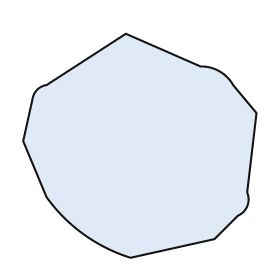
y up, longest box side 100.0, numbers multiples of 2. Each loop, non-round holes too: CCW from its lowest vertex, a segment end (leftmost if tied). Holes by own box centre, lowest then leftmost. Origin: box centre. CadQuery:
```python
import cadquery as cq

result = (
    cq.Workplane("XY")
    .moveTo(-4.0, -48.0)
    .lineTo(32.0, -40.0)
    .lineTo(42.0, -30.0)
    .threePointArc((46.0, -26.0), (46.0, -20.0))
    .lineTo(50.0, 14.0)
    .lineTo(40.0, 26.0)
    .threePointArc((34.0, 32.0), (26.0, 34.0))
    .lineTo(-6.0, 48.0)
    .lineTo(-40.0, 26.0)
    .threePointArc((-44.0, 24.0), (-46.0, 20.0))
    .lineTo(-50.0, 2.0)
    .lineTo(-40.0, -22.0)
    .threePointArc((-24.0, -38.0), (-4.0, -48.0))
    .close()
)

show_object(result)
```